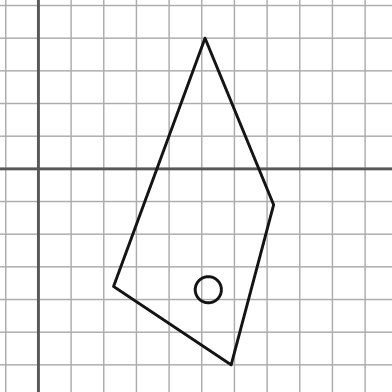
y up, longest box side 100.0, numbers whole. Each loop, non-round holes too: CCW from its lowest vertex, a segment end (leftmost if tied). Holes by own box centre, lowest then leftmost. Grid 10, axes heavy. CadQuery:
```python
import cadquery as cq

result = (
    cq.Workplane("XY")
    .moveTo(59.0, -60.0)
    .lineTo(72.0, -11.0)
    .lineTo(51.0, 40.0)
    .lineTo(23.0, -36.0)
    .close()
    .moveTo(52.0, -37.0)
    .circle(4.0)
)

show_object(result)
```